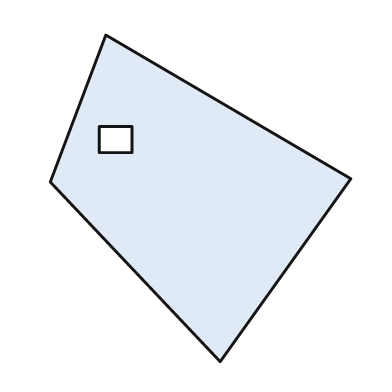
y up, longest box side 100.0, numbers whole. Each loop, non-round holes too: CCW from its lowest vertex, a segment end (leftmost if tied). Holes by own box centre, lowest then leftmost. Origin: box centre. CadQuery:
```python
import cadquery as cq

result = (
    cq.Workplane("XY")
    .moveTo(6.0, -50.0)
    .lineTo(46.0, 6.0)
    .lineTo(-29.0, 50.0)
    .lineTo(-46.0, 5.0)
    .close()
    .moveTo(-31.0, 14.0)
    .lineTo(-21.0, 14.0)
    .lineTo(-21.0, 22.0)
    .lineTo(-31.0, 22.0)
    .close()
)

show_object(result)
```